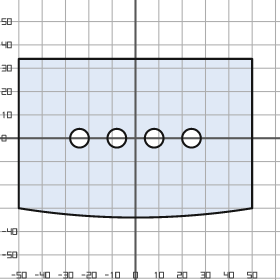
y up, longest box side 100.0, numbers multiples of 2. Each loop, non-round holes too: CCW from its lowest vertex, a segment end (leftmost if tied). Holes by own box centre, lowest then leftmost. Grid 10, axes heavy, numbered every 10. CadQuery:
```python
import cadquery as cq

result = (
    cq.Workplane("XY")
    .moveTo(-50.0, -30.0)
    .threePointArc((0.0, -34.0), (50.0, -30.0))
    .lineTo(50.0, 34.0)
    .lineTo(-50.0, 34.0)
    .close()
    .moveTo(-24.0, 0.0)
    .circle(4.0)
    .moveTo(-8.0, 0.0)
    .circle(4.0)
    .moveTo(8.0, 0.0)
    .circle(4.0)
    .moveTo(24.0, 0.0)
    .circle(4.0)
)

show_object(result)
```